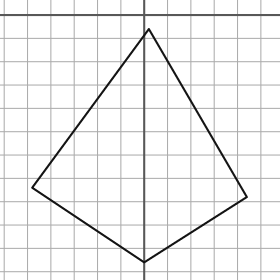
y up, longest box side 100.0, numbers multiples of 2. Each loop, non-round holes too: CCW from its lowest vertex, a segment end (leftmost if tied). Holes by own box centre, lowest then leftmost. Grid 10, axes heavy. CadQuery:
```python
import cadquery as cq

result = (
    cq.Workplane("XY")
    .moveTo(0.0, -106.0)
    .lineTo(44.0, -78.0)
    .lineTo(2.0, -6.0)
    .lineTo(-48.0, -74.0)
    .close()
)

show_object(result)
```